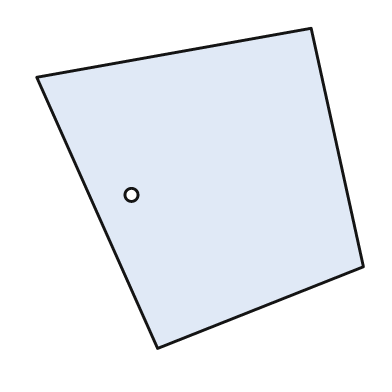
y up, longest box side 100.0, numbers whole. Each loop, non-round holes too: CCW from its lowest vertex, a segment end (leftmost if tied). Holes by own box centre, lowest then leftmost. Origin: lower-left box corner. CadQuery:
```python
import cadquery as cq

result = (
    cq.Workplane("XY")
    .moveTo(37.0, 0.0)
    .lineTo(100.0, 25.0)
    .lineTo(84.0, 98.0)
    .lineTo(0.0, 83.0)
    .close()
    .moveTo(29.0, 47.0)
    .circle(2.0)
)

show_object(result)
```